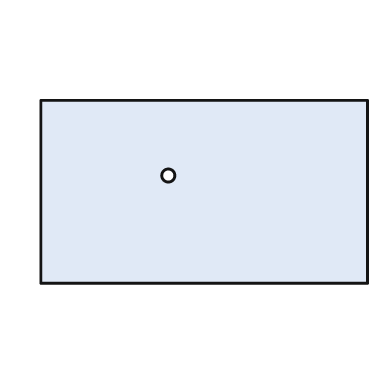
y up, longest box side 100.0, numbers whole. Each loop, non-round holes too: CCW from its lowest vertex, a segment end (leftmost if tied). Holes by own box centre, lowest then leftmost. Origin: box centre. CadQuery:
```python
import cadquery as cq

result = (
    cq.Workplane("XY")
    .moveTo(-50.0, -28.0)
    .lineTo(50.0, -28.0)
    .lineTo(50.0, 28.0)
    .lineTo(-50.0, 28.0)
    .close()
    .moveTo(-11.0, 5.0)
    .circle(2.0)
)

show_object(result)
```